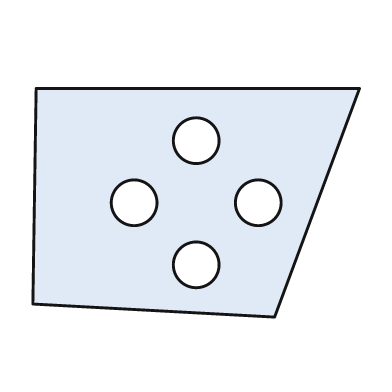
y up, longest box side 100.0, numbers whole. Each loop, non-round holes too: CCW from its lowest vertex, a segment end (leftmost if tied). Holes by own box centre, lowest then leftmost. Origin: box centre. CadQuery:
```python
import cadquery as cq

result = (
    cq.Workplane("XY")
    .moveTo(24.0, -35.0)
    .lineTo(50.0, 35.0)
    .lineTo(-49.0, 35.0)
    .lineTo(-50.0, -31.0)
    .close()
    .moveTo(0.0, -19.0)
    .circle(7.0)
    .moveTo(-19.0, 0.0)
    .circle(7.0)
    .moveTo(19.0, 0.0)
    .circle(7.0)
    .moveTo(0.0, 19.0)
    .circle(7.0)
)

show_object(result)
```